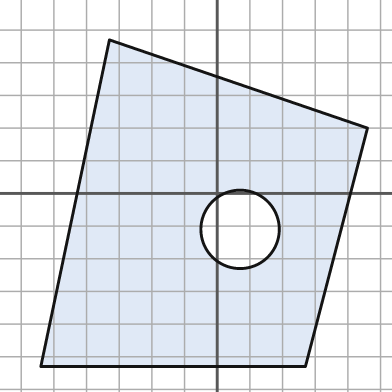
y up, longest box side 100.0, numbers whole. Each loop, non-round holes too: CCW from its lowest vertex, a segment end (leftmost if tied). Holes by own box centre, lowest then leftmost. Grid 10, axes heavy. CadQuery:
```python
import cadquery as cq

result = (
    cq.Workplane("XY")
    .moveTo(-54.0, -53.0)
    .lineTo(27.0, -53.0)
    .lineTo(46.0, 20.0)
    .lineTo(-33.0, 47.0)
    .close()
    .moveTo(7.0, -11.0)
    .circle(12.0)
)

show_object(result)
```